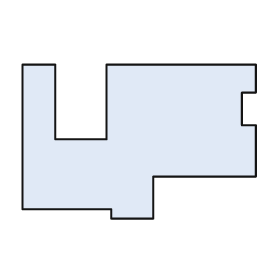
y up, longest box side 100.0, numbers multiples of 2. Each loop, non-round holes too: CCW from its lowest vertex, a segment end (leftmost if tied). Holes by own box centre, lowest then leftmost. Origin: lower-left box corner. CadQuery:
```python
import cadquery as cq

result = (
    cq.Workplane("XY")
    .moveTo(38.0, 0.0)
    .lineTo(56.0, 0.0)
    .lineTo(56.0, 18.0)
    .lineTo(100.0, 18.0)
    .lineTo(100.0, 40.0)
    .lineTo(94.0, 40.0)
    .lineTo(94.0, 54.0)
    .lineTo(100.0, 54.0)
    .lineTo(100.0, 66.0)
    .lineTo(36.0, 66.0)
    .lineTo(36.0, 34.0)
    .lineTo(14.0, 34.0)
    .lineTo(14.0, 66.0)
    .lineTo(0.0, 66.0)
    .lineTo(0.0, 4.0)
    .lineTo(38.0, 4.0)
    .close()
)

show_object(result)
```